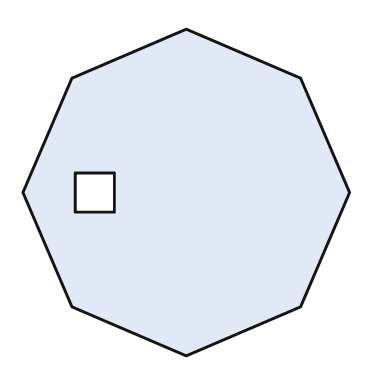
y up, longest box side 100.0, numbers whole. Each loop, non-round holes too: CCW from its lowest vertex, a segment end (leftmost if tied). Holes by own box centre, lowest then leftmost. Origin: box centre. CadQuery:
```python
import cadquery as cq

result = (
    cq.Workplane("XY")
    .moveTo(0.0, -50.0)
    .lineTo(35.0, -35.0)
    .lineTo(50.0, 0.0)
    .lineTo(35.0, 35.0)
    .lineTo(0.0, 50.0)
    .lineTo(-35.0, 35.0)
    .lineTo(-50.0, 0.0)
    .lineTo(-35.0, -35.0)
    .close()
    .moveTo(-34.0, -6.0)
    .lineTo(-22.0, -6.0)
    .lineTo(-22.0, 6.0)
    .lineTo(-34.0, 6.0)
    .close()
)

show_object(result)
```